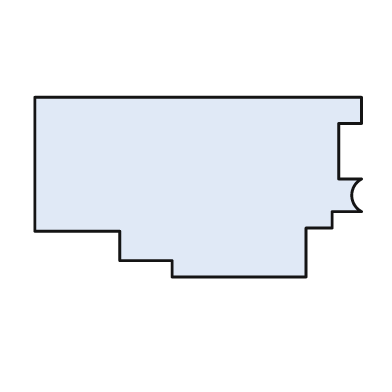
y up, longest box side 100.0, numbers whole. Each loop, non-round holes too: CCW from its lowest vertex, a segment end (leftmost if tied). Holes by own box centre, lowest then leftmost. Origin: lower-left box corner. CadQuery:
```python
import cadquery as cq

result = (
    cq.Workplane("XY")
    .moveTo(42.0, 0.0)
    .lineTo(83.0, 0.0)
    .lineTo(83.0, 15.0)
    .lineTo(91.0, 15.0)
    .lineTo(91.0, 20.0)
    .lineTo(100.0, 20.0)
    .threePointArc((97.0, 25.0), (100.0, 30.0))
    .lineTo(93.0, 30.0)
    .lineTo(93.0, 47.0)
    .lineTo(100.0, 47.0)
    .lineTo(100.0, 55.0)
    .lineTo(0.0, 55.0)
    .lineTo(0.0, 14.0)
    .lineTo(26.0, 14.0)
    .lineTo(26.0, 5.0)
    .lineTo(42.0, 5.0)
    .close()
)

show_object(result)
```